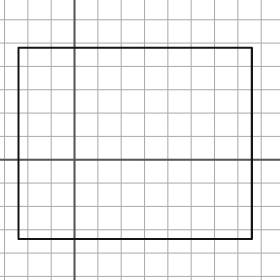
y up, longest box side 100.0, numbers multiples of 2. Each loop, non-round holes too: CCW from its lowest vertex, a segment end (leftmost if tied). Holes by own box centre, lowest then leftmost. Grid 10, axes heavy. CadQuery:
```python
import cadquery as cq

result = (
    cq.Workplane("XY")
    .moveTo(-24.0, -34.0)
    .lineTo(76.0, -34.0)
    .lineTo(76.0, 48.0)
    .lineTo(-24.0, 48.0)
    .close()
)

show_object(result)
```